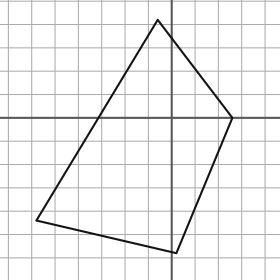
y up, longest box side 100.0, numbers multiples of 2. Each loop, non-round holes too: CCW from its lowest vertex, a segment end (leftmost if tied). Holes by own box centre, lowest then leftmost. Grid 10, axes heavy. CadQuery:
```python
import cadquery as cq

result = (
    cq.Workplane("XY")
    .moveTo(2.0, -58.0)
    .lineTo(26.0, 0.0)
    .lineTo(-6.0, 42.0)
    .lineTo(-58.0, -44.0)
    .close()
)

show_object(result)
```